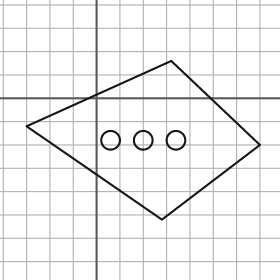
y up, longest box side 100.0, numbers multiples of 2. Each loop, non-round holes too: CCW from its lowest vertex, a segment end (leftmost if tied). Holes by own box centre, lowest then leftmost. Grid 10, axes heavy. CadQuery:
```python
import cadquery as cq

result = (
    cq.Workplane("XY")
    .moveTo(28.0, -52.0)
    .lineTo(70.0, -20.0)
    .lineTo(32.0, 16.0)
    .lineTo(-30.0, -12.0)
    .close()
    .moveTo(6.0, -18.0)
    .circle(4.0)
    .moveTo(20.0, -18.0)
    .circle(4.0)
    .moveTo(34.0, -18.0)
    .circle(4.0)
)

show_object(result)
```